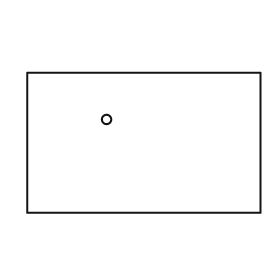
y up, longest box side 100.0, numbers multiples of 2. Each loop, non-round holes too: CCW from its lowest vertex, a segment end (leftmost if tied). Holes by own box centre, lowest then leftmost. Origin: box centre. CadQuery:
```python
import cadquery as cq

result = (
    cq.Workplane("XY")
    .moveTo(-50.0, -30.0)
    .lineTo(50.0, -30.0)
    .lineTo(50.0, 30.0)
    .lineTo(-50.0, 30.0)
    .close()
    .moveTo(-16.0, 10.0)
    .circle(2.0)
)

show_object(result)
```